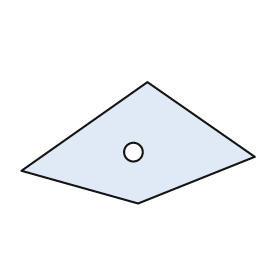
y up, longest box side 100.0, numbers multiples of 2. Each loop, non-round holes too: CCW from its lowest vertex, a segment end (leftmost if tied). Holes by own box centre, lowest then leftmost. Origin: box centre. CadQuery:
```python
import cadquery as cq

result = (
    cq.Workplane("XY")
    .moveTo(0.0, -26.0)
    .lineTo(50.0, -6.0)
    .lineTo(4.0, 26.0)
    .lineTo(-50.0, -12.0)
    .close()
    .moveTo(-2.0, -4.0)
    .circle(4.0)
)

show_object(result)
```